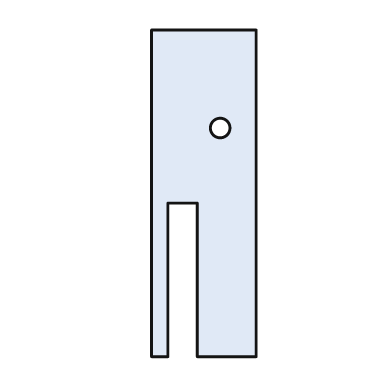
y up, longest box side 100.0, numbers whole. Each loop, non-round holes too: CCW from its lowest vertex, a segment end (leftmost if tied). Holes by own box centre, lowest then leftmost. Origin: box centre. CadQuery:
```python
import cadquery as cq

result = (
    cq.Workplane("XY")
    .moveTo(-16.0, -50.0)
    .lineTo(-11.0, -50.0)
    .lineTo(-11.0, -3.0)
    .lineTo(-2.0, -3.0)
    .lineTo(-2.0, -50.0)
    .lineTo(16.0, -50.0)
    .lineTo(16.0, 50.0)
    .lineTo(-16.0, 50.0)
    .close()
    .moveTo(5.0, 20.0)
    .circle(3.0)
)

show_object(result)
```